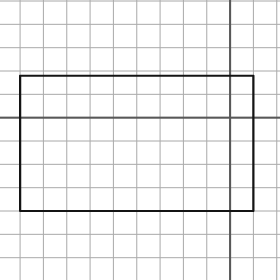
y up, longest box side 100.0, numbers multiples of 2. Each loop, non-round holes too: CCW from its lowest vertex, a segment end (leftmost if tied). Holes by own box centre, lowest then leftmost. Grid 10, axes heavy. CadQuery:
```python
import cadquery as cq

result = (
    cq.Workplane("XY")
    .moveTo(-90.0, -40.0)
    .lineTo(10.0, -40.0)
    .lineTo(10.0, 18.0)
    .lineTo(-90.0, 18.0)
    .close()
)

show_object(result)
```